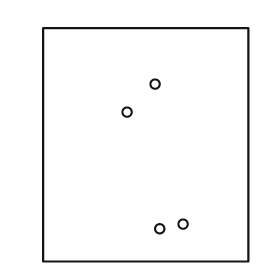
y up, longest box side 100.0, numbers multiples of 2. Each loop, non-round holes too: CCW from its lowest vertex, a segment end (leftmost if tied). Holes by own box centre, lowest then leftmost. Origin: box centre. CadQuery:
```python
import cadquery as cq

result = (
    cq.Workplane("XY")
    .moveTo(-44.0, -50.0)
    .lineTo(44.0, -50.0)
    .lineTo(44.0, 50.0)
    .lineTo(-44.0, 50.0)
    .close()
    .moveTo(6.0, -36.0)
    .circle(2.0)
    .moveTo(16.0, -34.0)
    .circle(2.0)
    .moveTo(-8.0, 14.0)
    .circle(2.0)
    .moveTo(4.0, 26.0)
    .circle(2.0)
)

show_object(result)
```